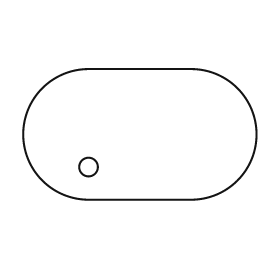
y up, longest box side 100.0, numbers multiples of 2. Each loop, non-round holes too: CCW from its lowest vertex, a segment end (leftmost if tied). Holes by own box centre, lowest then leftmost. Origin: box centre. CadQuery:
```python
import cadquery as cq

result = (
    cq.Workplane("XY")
    .moveTo(-22.0, -28.0)
    .lineTo(22.0, -28.0)
    .threePointArc((50.0, 0.0), (22.0, 28.0))
    .lineTo(-22.0, 28.0)
    .threePointArc((-50.0, 0.0), (-22.0, -28.0))
    .close()
    .moveTo(-22.0, -14.0)
    .circle(4.0)
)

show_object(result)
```